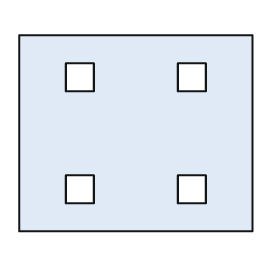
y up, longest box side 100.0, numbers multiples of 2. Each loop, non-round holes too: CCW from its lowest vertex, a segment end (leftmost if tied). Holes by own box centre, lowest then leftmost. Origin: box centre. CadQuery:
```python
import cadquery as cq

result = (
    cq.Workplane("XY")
    .moveTo(-50.0, -42.0)
    .lineTo(50.0, -42.0)
    .lineTo(50.0, 42.0)
    .lineTo(-50.0, 42.0)
    .close()
    .moveTo(-30.0, -30.0)
    .lineTo(-18.0, -30.0)
    .lineTo(-18.0, -18.0)
    .lineTo(-30.0, -18.0)
    .close()
    .moveTo(18.0, -30.0)
    .lineTo(30.0, -30.0)
    .lineTo(30.0, -18.0)
    .lineTo(18.0, -18.0)
    .close()
    .moveTo(-30.0, 18.0)
    .lineTo(-18.0, 18.0)
    .lineTo(-18.0, 30.0)
    .lineTo(-30.0, 30.0)
    .close()
    .moveTo(18.0, 18.0)
    .lineTo(30.0, 18.0)
    .lineTo(30.0, 30.0)
    .lineTo(18.0, 30.0)
    .close()
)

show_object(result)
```